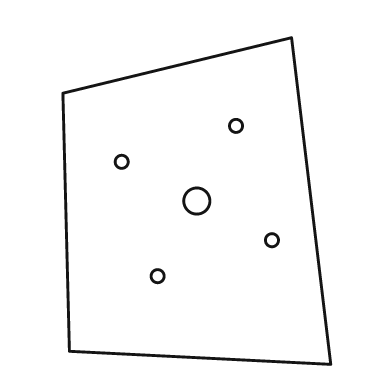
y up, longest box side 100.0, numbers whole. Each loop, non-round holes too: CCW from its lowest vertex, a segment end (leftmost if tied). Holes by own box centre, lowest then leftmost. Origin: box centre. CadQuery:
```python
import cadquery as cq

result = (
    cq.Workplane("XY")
    .moveTo(41.0, -50.0)
    .lineTo(29.0, 50.0)
    .lineTo(-41.0, 33.0)
    .lineTo(-39.0, -46.0)
    .close()
    .moveTo(-12.0, -23.0)
    .circle(2.0)
    .moveTo(23.0, -12.0)
    .circle(2.0)
    .moveTo(0.0, 0.0)
    .circle(4.0)
    .moveTo(-23.0, 12.0)
    .circle(2.0)
    .moveTo(12.0, 23.0)
    .circle(2.0)
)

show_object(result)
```